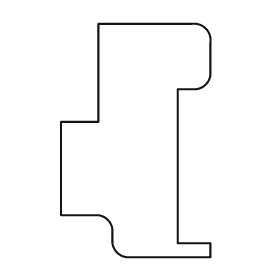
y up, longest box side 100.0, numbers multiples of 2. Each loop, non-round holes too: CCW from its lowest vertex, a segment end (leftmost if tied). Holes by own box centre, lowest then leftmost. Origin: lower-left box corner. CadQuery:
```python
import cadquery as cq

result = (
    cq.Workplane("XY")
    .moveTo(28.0, 0.0)
    .lineTo(64.0, 0.0)
    .lineTo(64.0, 6.0)
    .lineTo(50.0, 6.0)
    .lineTo(50.0, 72.0)
    .lineTo(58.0, 72.0)
    .threePointArc((62.0, 74.0), (64.0, 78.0))
    .lineTo(64.0, 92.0)
    .threePointArc((62.0, 98.0), (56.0, 100.0))
    .lineTo(16.0, 100.0)
    .lineTo(16.0, 58.0)
    .lineTo(0.0, 58.0)
    .lineTo(0.0, 18.0)
    .lineTo(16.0, 18.0)
    .threePointArc((20.0, 16.0), (22.0, 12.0))
    .lineTo(22.0, 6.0)
    .threePointArc((24.0, 2.0), (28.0, 0.0))
    .close()
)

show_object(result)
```